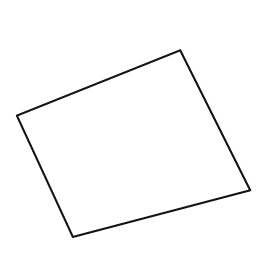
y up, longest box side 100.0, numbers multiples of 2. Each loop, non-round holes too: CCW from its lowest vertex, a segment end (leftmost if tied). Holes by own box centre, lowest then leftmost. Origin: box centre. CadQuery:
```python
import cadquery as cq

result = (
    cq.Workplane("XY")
    .moveTo(-26.0, -40.0)
    .lineTo(50.0, -20.0)
    .lineTo(20.0, 40.0)
    .lineTo(-50.0, 12.0)
    .close()
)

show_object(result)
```